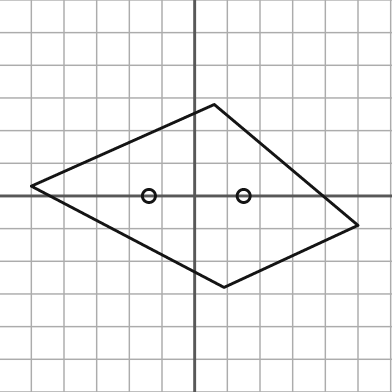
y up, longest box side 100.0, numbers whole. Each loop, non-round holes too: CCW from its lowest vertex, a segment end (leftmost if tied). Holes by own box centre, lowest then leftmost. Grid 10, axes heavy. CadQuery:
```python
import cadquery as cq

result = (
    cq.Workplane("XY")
    .moveTo(9.0, -28.0)
    .lineTo(50.0, -9.0)
    .lineTo(6.0, 28.0)
    .lineTo(-50.0, 3.0)
    .close()
    .moveTo(-14.0, 0.0)
    .circle(2.0)
    .moveTo(15.0, 0.0)
    .circle(2.0)
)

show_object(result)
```